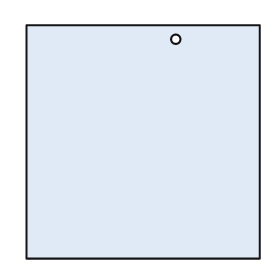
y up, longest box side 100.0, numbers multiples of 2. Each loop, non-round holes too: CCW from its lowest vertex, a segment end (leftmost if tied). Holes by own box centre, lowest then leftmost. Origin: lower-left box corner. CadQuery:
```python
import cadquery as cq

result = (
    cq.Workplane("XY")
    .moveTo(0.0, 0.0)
    .lineTo(100.0, 0.0)
    .lineTo(100.0, 100.0)
    .lineTo(0.0, 100.0)
    .close()
    .moveTo(64.0, 94.0)
    .circle(2.0)
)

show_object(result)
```